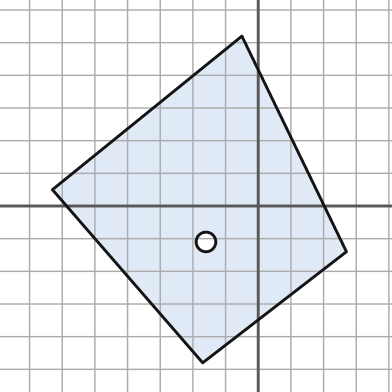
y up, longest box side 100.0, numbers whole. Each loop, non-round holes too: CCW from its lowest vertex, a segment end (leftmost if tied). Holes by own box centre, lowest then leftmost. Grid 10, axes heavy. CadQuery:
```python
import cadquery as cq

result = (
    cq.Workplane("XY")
    .moveTo(-17.0, -48.0)
    .lineTo(27.0, -14.0)
    .lineTo(-5.0, 52.0)
    .lineTo(-63.0, 5.0)
    .close()
    .moveTo(-16.0, -11.0)
    .circle(3.0)
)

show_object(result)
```